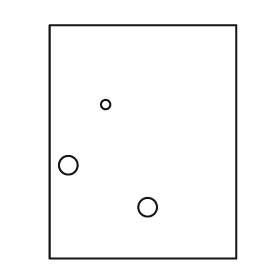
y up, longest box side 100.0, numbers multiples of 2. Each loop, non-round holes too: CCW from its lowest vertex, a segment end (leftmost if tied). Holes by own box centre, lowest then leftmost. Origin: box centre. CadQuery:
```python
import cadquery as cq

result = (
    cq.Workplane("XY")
    .moveTo(-40.0, -50.0)
    .lineTo(40.0, -50.0)
    .lineTo(40.0, 50.0)
    .lineTo(-40.0, 50.0)
    .close()
    .moveTo(2.0, -28.0)
    .circle(4.0)
    .moveTo(-32.0, -10.0)
    .circle(4.0)
    .moveTo(-16.0, 16.0)
    .circle(2.0)
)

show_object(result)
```